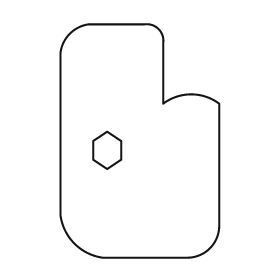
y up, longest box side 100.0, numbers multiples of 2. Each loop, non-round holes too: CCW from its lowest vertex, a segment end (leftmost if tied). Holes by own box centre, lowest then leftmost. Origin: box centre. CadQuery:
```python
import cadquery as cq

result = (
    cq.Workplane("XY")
    .moveTo(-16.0, -50.0)
    .lineTo(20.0, -50.0)
    .threePointArc((30.0, -46.0), (34.0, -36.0))
    .lineTo(34.0, 16.0)
    .threePointArc((22.0, 20.0), (10.0, 16.0))
    .lineTo(10.0, 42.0)
    .threePointArc((8.0, 48.0), (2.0, 50.0))
    .lineTo(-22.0, 50.0)
    .threePointArc((-30.0, 46.0), (-34.0, 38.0))
    .lineTo(-34.0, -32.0)
    .threePointArc((-28.0, -44.0), (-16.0, -50.0))
    .close()
    .moveTo(-14.0, -12.0)
    .lineTo(-8.0, -8.0)
    .lineTo(-8.0, 0.0)
    .lineTo(-14.0, 4.0)
    .lineTo(-20.0, 0.0)
    .lineTo(-20.0, -8.0)
    .close()
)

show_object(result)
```